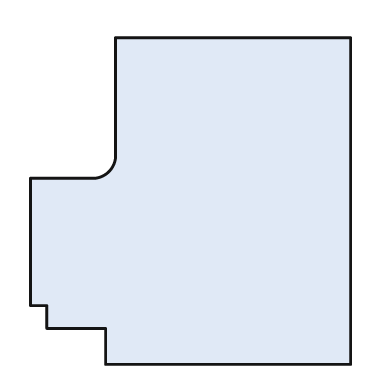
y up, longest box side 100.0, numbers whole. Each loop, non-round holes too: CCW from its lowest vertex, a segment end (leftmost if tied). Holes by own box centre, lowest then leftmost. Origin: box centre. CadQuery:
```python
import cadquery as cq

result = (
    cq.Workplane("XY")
    .moveTo(-26.0, -50.0)
    .lineTo(49.0, -50.0)
    .lineTo(49.0, 50.0)
    .lineTo(-23.0, 50.0)
    .lineTo(-23.0, 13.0)
    .threePointArc((-25.0, 9.0), (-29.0, 7.0))
    .lineTo(-49.0, 7.0)
    .lineTo(-49.0, -32.0)
    .lineTo(-44.0, -32.0)
    .lineTo(-44.0, -39.0)
    .lineTo(-26.0, -39.0)
    .close()
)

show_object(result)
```